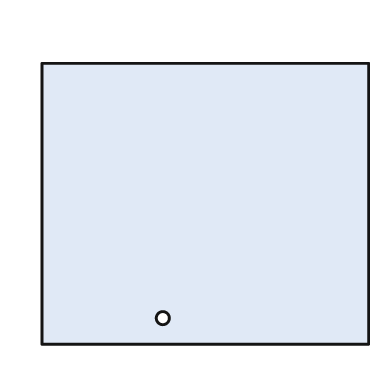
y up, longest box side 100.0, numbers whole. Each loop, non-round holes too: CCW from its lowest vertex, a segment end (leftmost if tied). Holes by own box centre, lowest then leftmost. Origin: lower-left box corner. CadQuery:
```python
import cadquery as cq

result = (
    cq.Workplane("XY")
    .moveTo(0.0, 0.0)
    .lineTo(100.0, 0.0)
    .lineTo(100.0, 86.0)
    .lineTo(0.0, 86.0)
    .close()
    .moveTo(37.0, 8.0)
    .circle(2.0)
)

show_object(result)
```